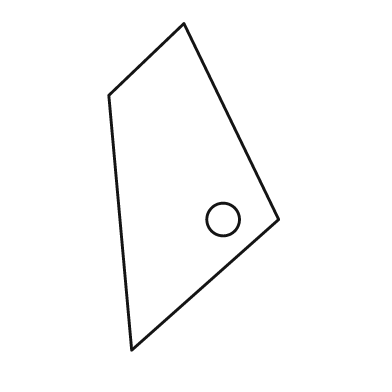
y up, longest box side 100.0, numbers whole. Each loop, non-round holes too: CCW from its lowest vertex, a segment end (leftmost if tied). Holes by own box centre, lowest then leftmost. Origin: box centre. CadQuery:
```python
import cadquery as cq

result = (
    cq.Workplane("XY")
    .moveTo(-19.0, -50.0)
    .lineTo(26.0, -10.0)
    .lineTo(-3.0, 50.0)
    .lineTo(-26.0, 28.0)
    .close()
    .moveTo(9.0, -10.0)
    .circle(5.0)
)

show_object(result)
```